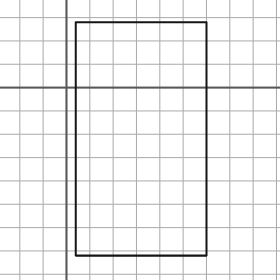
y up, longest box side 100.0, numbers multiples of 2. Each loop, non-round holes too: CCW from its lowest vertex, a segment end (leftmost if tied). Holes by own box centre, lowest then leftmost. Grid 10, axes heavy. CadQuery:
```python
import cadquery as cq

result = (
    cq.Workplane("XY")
    .moveTo(4.0, -72.0)
    .lineTo(60.0, -72.0)
    .lineTo(60.0, 28.0)
    .lineTo(4.0, 28.0)
    .close()
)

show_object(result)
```